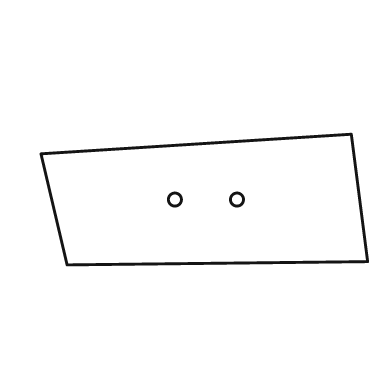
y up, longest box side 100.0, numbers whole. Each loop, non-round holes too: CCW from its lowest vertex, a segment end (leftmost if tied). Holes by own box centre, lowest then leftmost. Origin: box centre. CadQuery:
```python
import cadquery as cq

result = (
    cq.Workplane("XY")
    .moveTo(-42.0, -20.0)
    .lineTo(50.0, -19.0)
    .lineTo(45.0, 20.0)
    .lineTo(-50.0, 14.0)
    .close()
    .moveTo(-9.0, 0.0)
    .circle(2.0)
    .moveTo(10.0, 0.0)
    .circle(2.0)
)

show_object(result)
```